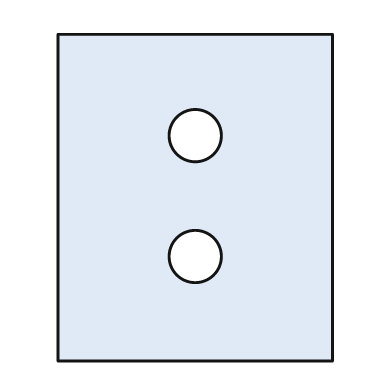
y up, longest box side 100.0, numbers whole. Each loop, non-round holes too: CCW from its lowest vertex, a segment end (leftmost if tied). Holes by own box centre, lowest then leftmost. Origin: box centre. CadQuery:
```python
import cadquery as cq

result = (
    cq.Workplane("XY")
    .moveTo(-42.0, -50.0)
    .lineTo(42.0, -50.0)
    .lineTo(42.0, 50.0)
    .lineTo(-42.0, 50.0)
    .close()
    .moveTo(0.0, -18.0)
    .circle(8.0)
    .moveTo(0.0, 19.0)
    .circle(8.0)
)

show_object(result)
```